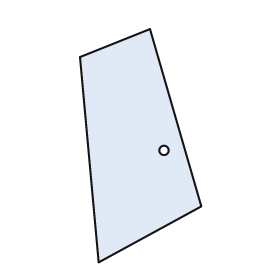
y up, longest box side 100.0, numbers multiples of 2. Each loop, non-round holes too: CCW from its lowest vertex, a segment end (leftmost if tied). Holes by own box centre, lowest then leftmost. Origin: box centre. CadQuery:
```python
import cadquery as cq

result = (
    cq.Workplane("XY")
    .moveTo(-18.0, -50.0)
    .lineTo(26.0, -26.0)
    .lineTo(4.0, 50.0)
    .lineTo(-26.0, 38.0)
    .close()
    .moveTo(10.0, -2.0)
    .circle(2.0)
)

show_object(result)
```